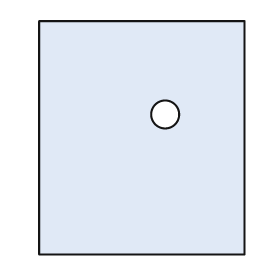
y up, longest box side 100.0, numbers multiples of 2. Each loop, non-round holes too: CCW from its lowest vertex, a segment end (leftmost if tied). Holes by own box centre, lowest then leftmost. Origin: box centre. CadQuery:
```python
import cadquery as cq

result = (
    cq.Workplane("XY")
    .moveTo(-44.0, -50.0)
    .lineTo(44.0, -50.0)
    .lineTo(44.0, 50.0)
    .lineTo(-44.0, 50.0)
    .close()
    .moveTo(10.0, 10.0)
    .circle(6.0)
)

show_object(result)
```